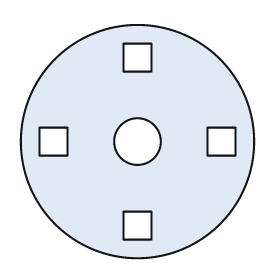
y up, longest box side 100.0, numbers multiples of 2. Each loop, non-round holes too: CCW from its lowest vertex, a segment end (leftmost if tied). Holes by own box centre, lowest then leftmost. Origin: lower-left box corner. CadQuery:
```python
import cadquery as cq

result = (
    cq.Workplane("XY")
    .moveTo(50.0, 50.0)
    .circle(50.0)
    .moveTo(44.0, 8.0)
    .lineTo(56.0, 8.0)
    .lineTo(56.0, 20.0)
    .lineTo(44.0, 20.0)
    .close()
    .moveTo(8.0, 44.0)
    .lineTo(20.0, 44.0)
    .lineTo(20.0, 56.0)
    .lineTo(8.0, 56.0)
    .close()
    .moveTo(50.0, 50.0)
    .circle(10.0)
    .moveTo(80.0, 44.0)
    .lineTo(92.0, 44.0)
    .lineTo(92.0, 56.0)
    .lineTo(80.0, 56.0)
    .close()
    .moveTo(44.0, 80.0)
    .lineTo(56.0, 80.0)
    .lineTo(56.0, 92.0)
    .lineTo(44.0, 92.0)
    .close()
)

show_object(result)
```